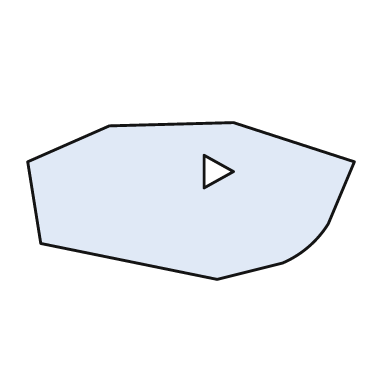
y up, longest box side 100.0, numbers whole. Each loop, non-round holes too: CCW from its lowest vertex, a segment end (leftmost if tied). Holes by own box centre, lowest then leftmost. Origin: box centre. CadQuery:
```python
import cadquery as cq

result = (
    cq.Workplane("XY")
    .moveTo(8.0, -24.0)
    .lineTo(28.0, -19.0)
    .threePointArc((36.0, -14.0), (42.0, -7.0))
    .lineTo(50.0, 12.0)
    .lineTo(13.0, 24.0)
    .lineTo(-25.0, 23.0)
    .lineTo(-50.0, 12.0)
    .lineTo(-46.0, -13.0)
    .close()
    .moveTo(4.0, 4.0)
    .lineTo(13.0, 9.0)
    .lineTo(4.0, 14.0)
    .close()
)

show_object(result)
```